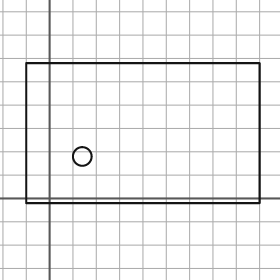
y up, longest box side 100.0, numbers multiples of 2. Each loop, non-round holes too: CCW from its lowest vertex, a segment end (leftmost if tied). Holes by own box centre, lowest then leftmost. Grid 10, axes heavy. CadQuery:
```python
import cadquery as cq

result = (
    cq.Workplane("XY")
    .moveTo(-10.0, -2.0)
    .lineTo(90.0, -2.0)
    .lineTo(90.0, 58.0)
    .lineTo(-10.0, 58.0)
    .close()
    .moveTo(14.0, 18.0)
    .circle(4.0)
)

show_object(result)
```